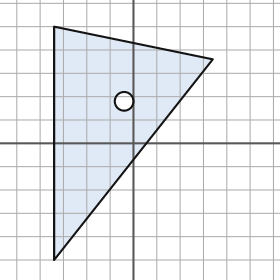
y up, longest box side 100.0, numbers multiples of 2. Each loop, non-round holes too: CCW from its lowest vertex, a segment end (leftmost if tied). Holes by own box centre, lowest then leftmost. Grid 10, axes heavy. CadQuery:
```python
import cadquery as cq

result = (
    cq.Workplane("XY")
    .moveTo(-34.0, -50.0)
    .lineTo(34.0, 36.0)
    .lineTo(-34.0, 50.0)
    .close()
    .moveTo(-4.0, 18.0)
    .circle(4.0)
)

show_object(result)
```